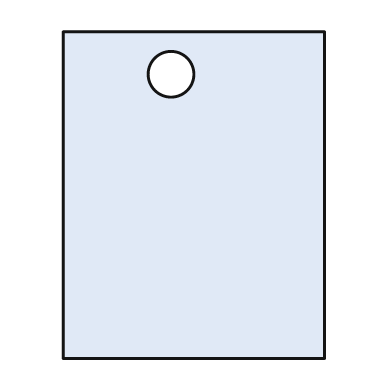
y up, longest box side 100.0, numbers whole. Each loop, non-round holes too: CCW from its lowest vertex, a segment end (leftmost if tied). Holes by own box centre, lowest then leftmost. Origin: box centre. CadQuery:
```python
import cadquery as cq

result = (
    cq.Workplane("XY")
    .moveTo(-40.0, -50.0)
    .lineTo(40.0, -50.0)
    .lineTo(40.0, 50.0)
    .lineTo(-40.0, 50.0)
    .close()
    .moveTo(-7.0, 37.0)
    .circle(7.0)
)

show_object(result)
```